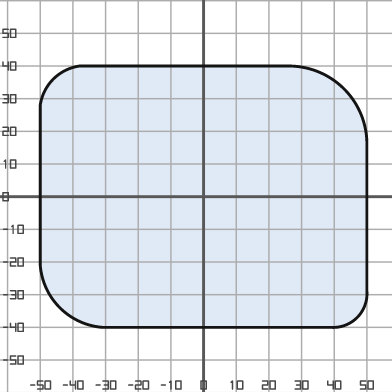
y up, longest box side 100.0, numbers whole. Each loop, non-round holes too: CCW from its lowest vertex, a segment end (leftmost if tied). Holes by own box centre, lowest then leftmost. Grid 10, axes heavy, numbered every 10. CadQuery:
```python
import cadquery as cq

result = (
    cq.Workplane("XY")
    .moveTo(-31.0, -40.0)
    .lineTo(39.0, -40.0)
    .threePointArc((47.0, -37.0), (50.0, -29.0))
    .lineTo(50.0, 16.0)
    .threePointArc((43.0, 33.0), (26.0, 40.0))
    .lineTo(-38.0, 40.0)
    .threePointArc((-46.0, 36.0), (-50.0, 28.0))
    .lineTo(-50.0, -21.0)
    .threePointArc((-44.0, -34.0), (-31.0, -40.0))
    .close()
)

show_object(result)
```